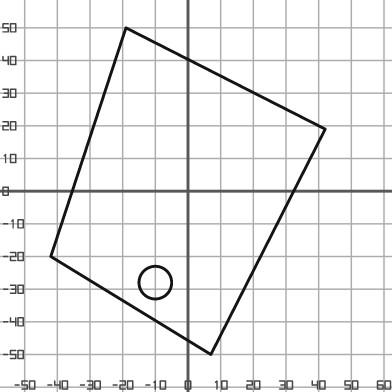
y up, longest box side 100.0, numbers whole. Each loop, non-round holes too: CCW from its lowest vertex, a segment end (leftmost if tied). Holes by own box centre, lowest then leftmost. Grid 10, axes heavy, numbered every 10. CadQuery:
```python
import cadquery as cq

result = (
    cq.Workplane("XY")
    .moveTo(7.0, -50.0)
    .lineTo(42.0, 19.0)
    .lineTo(-19.0, 50.0)
    .lineTo(-42.0, -20.0)
    .close()
    .moveTo(-10.0, -28.0)
    .circle(5.0)
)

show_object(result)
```